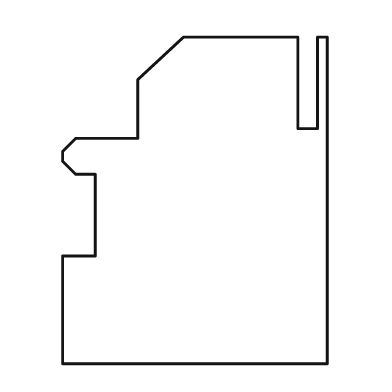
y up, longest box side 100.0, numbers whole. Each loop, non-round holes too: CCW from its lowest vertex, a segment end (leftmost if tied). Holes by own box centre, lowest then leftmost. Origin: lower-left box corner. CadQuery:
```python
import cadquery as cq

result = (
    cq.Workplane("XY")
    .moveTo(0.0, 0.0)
    .lineTo(81.0, 0.0)
    .lineTo(81.0, 100.0)
    .lineTo(78.0, 100.0)
    .lineTo(78.0, 72.0)
    .lineTo(72.0, 72.0)
    .lineTo(72.0, 100.0)
    .lineTo(37.0, 100.0)
    .lineTo(23.0, 87.0)
    .lineTo(23.0, 69.0)
    .lineTo(4.0, 69.0)
    .lineTo(0.0, 65.0)
    .lineTo(0.0, 62.0)
    .lineTo(4.0, 58.0)
    .lineTo(10.0, 58.0)
    .lineTo(10.0, 33.0)
    .lineTo(0.0, 33.0)
    .close()
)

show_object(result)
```